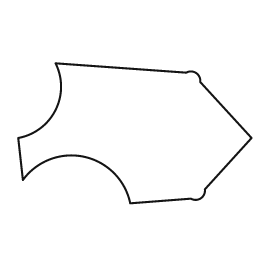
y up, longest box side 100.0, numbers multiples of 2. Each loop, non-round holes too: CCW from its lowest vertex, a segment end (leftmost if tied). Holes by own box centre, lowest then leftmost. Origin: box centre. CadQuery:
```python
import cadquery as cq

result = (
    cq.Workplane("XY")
    .moveTo(-2.0, -30.0)
    .lineTo(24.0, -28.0)
    .threePointArc((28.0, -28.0), (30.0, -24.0))
    .lineTo(50.0, -2.0)
    .lineTo(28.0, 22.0)
    .threePointArc((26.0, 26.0), (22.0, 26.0))
    .lineTo(-34.0, 30.0)
    .threePointArc((-34.0, 10.0), (-50.0, -2.0))
    .lineTo(-48.0, -20.0)
    .threePointArc((-22.0, -10.0), (-2.0, -30.0))
    .close()
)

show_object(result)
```